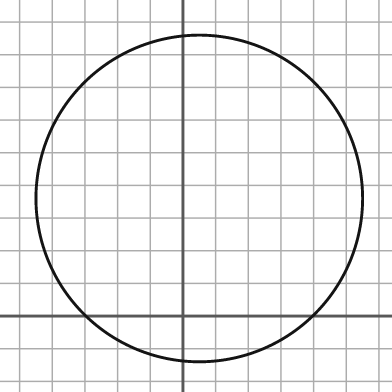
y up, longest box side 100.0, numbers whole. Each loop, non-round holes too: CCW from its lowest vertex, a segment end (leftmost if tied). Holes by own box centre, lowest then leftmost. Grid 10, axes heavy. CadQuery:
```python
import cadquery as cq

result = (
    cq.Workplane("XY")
    .moveTo(5.0, 36.0)
    .circle(50.0)
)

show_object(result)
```